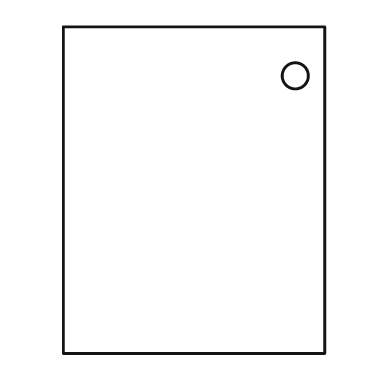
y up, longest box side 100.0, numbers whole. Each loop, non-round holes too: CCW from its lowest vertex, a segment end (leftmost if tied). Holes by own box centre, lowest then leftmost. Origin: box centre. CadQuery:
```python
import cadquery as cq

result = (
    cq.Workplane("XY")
    .moveTo(-40.0, -50.0)
    .lineTo(40.0, -50.0)
    .lineTo(40.0, 50.0)
    .lineTo(-40.0, 50.0)
    .close()
    .moveTo(31.0, 35.0)
    .circle(4.0)
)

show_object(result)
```